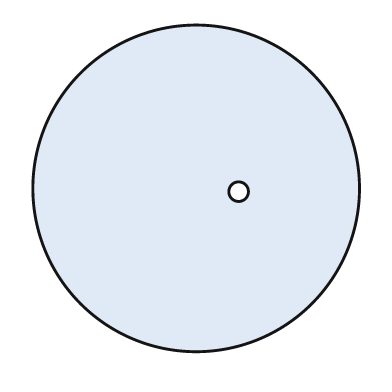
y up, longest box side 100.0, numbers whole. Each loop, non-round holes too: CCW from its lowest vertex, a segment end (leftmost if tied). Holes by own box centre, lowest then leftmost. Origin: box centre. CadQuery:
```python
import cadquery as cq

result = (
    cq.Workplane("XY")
    .moveTo(0.0, 0.0)
    .circle(50.0)
    .moveTo(13.0, -1.0)
    .circle(3.0)
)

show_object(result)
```